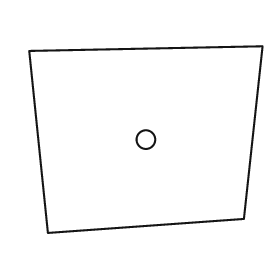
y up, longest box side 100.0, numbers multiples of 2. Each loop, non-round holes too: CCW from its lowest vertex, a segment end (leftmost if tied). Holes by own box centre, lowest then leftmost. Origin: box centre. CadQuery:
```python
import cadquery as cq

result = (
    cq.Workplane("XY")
    .moveTo(-42.0, -40.0)
    .lineTo(42.0, -34.0)
    .lineTo(50.0, 40.0)
    .lineTo(-50.0, 38.0)
    .close()
    .moveTo(0.0, 0.0)
    .circle(4.0)
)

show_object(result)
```